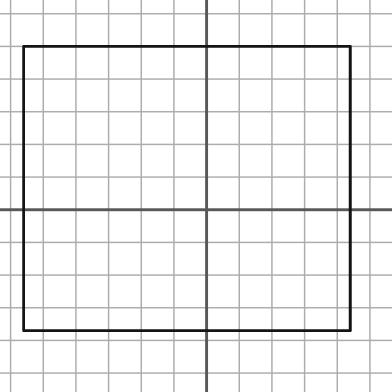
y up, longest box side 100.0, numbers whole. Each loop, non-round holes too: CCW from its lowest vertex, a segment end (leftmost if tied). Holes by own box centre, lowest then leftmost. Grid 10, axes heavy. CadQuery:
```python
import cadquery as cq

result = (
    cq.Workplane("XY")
    .moveTo(-56.0, -37.0)
    .lineTo(44.0, -37.0)
    .lineTo(44.0, 50.0)
    .lineTo(-56.0, 50.0)
    .close()
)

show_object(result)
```